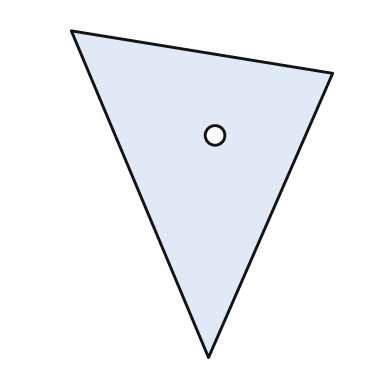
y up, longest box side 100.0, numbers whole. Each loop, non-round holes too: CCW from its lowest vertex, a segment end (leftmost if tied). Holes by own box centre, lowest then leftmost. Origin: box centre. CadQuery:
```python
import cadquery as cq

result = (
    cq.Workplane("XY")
    .moveTo(2.0, -50.0)
    .lineTo(40.0, 37.0)
    .lineTo(-40.0, 50.0)
    .close()
    .moveTo(4.0, 18.0)
    .circle(3.0)
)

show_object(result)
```